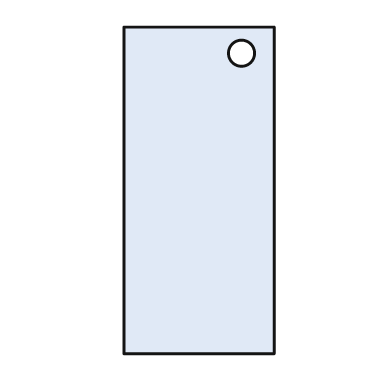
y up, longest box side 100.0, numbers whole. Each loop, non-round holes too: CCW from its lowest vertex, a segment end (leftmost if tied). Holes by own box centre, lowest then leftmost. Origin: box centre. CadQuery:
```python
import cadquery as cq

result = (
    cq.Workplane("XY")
    .moveTo(-23.0, -50.0)
    .lineTo(23.0, -50.0)
    .lineTo(23.0, 50.0)
    .lineTo(-23.0, 50.0)
    .close()
    .moveTo(13.0, 42.0)
    .circle(4.0)
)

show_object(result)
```